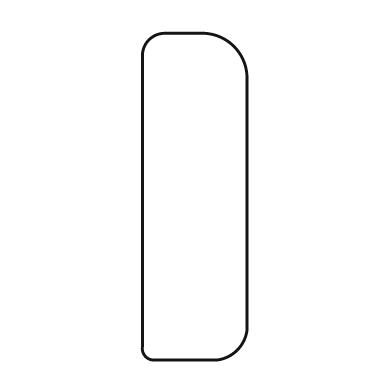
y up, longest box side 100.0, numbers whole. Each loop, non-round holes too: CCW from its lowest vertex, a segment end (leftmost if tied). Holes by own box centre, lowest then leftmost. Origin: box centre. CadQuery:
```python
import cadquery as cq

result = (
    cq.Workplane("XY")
    .moveTo(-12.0, -50.0)
    .lineTo(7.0, -50.0)
    .threePointArc((13.0, -47.0), (16.0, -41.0))
    .lineTo(16.0, 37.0)
    .threePointArc((12.0, 46.0), (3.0, 50.0))
    .lineTo(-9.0, 50.0)
    .threePointArc((-14.0, 48.0), (-16.0, 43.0))
    .lineTo(-16.0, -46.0)
    .threePointArc((-15.0, -49.0), (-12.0, -50.0))
    .close()
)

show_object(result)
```